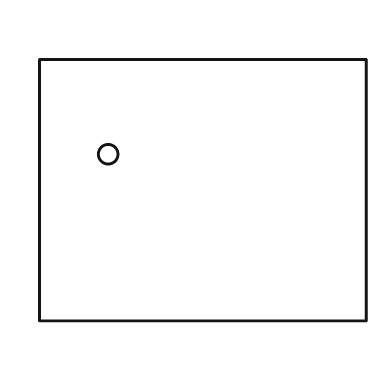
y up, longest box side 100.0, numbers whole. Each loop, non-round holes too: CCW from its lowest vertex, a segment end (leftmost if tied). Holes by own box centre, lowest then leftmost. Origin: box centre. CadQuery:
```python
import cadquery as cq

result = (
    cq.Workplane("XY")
    .moveTo(-50.0, -40.0)
    .lineTo(50.0, -40.0)
    .lineTo(50.0, 40.0)
    .lineTo(-50.0, 40.0)
    .close()
    .moveTo(-29.0, 11.0)
    .circle(3.0)
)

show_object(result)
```